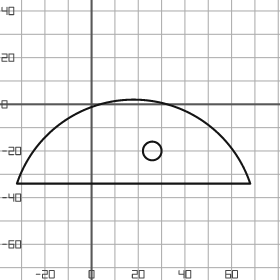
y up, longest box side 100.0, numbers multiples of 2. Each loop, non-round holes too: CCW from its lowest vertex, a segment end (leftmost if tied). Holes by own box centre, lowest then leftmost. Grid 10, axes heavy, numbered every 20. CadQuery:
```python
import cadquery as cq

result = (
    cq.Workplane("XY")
    .moveTo(-32.0, -34.0)
    .lineTo(68.0, -34.0)
    .threePointArc((18.0, 2.0), (-32.0, -34.0))
    .close()
    .moveTo(26.0, -20.0)
    .circle(4.0)
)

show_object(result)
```